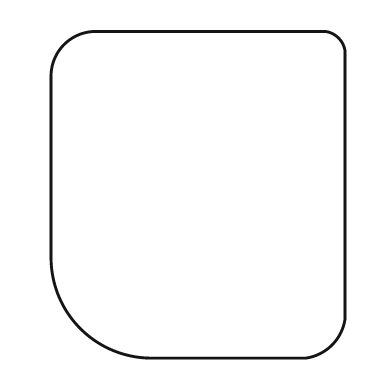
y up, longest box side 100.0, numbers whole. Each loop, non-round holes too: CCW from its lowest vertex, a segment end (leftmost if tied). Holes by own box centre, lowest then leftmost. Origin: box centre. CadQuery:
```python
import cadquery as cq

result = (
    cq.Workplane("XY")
    .moveTo(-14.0, -50.0)
    .lineTo(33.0, -50.0)
    .threePointArc((41.0, -46.0), (45.0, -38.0))
    .lineTo(45.0, 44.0)
    .threePointArc((43.0, 48.0), (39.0, 50.0))
    .lineTo(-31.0, 50.0)
    .threePointArc((-41.0, 46.0), (-45.0, 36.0))
    .lineTo(-45.0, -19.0)
    .threePointArc((-36.0, -41.0), (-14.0, -50.0))
    .close()
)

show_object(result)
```